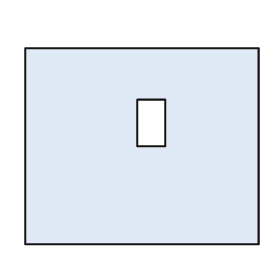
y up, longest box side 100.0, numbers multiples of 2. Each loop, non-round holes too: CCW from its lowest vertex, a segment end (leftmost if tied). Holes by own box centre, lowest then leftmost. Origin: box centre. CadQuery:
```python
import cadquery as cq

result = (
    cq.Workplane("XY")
    .moveTo(-50.0, -42.0)
    .lineTo(50.0, -42.0)
    .lineTo(50.0, 42.0)
    .lineTo(-50.0, 42.0)
    .close()
    .moveTo(-2.0, 0.0)
    .lineTo(10.0, 0.0)
    .lineTo(10.0, 20.0)
    .lineTo(-2.0, 20.0)
    .close()
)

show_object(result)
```